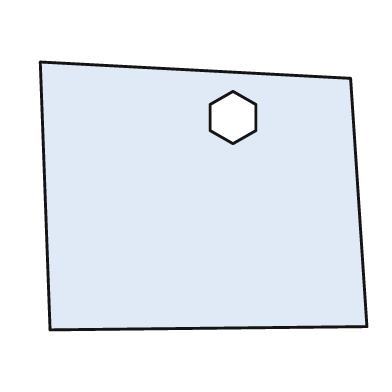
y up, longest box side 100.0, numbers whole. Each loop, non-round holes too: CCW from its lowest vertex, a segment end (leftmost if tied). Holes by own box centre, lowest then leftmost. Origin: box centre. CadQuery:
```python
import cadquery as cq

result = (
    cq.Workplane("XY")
    .moveTo(-47.0, -41.0)
    .lineTo(50.0, -40.0)
    .lineTo(45.0, 36.0)
    .lineTo(-50.0, 41.0)
    .close()
    .moveTo(9.0, 16.0)
    .lineTo(16.0, 20.0)
    .lineTo(16.0, 28.0)
    .lineTo(9.0, 32.0)
    .lineTo(2.0, 28.0)
    .lineTo(2.0, 20.0)
    .close()
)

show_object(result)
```